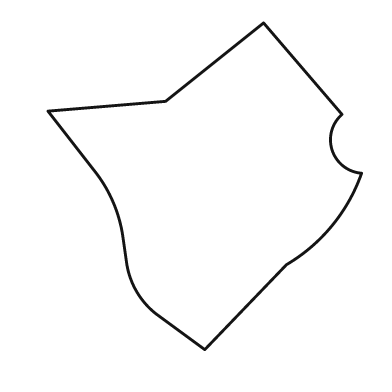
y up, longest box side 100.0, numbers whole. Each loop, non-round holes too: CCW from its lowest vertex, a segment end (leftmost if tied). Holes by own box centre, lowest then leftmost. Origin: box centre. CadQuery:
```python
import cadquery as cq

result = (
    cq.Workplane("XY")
    .moveTo(0.0, -50.0)
    .lineTo(25.0, -24.0)
    .threePointArc((39.0, -12.0), (48.0, 4.0))
    .threePointArc((39.0, 11.0), (42.0, 22.0))
    .lineTo(18.0, 50.0)
    .lineTo(-12.0, 26.0)
    .lineTo(-48.0, 23.0)
    .lineTo(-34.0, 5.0)
    .threePointArc((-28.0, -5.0), (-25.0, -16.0))
    .lineTo(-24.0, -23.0)
    .threePointArc((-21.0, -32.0), (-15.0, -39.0))
    .close()
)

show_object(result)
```